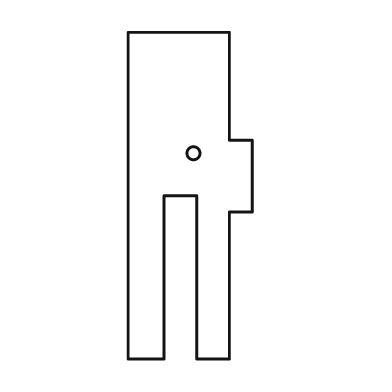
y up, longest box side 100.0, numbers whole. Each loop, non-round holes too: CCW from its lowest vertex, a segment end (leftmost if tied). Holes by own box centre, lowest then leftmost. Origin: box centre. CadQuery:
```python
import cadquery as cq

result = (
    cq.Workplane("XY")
    .moveTo(-19.0, -50.0)
    .lineTo(-8.0, -50.0)
    .lineTo(-8.0, 0.0)
    .lineTo(2.0, 0.0)
    .lineTo(2.0, -50.0)
    .lineTo(12.0, -50.0)
    .lineTo(12.0, -5.0)
    .lineTo(19.0, -5.0)
    .lineTo(19.0, 17.0)
    .lineTo(12.0, 17.0)
    .lineTo(12.0, 50.0)
    .lineTo(-19.0, 50.0)
    .close()
    .moveTo(1.0, 13.0)
    .circle(2.0)
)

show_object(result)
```